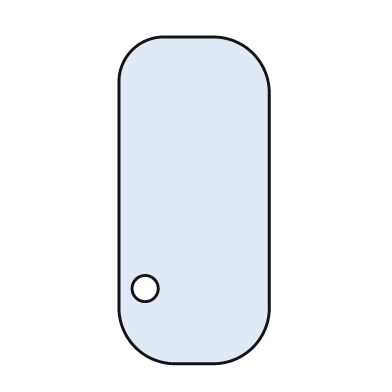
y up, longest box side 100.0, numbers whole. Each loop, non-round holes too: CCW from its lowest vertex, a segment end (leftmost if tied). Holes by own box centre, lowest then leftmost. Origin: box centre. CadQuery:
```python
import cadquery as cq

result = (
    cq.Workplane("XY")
    .moveTo(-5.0, -50.0)
    .lineTo(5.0, -50.0)
    .threePointArc((18.0, -45.0), (23.0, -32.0))
    .lineTo(23.0, 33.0)
    .threePointArc((18.0, 45.0), (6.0, 50.0))
    .lineTo(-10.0, 50.0)
    .threePointArc((-19.0, 46.0), (-23.0, 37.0))
    .lineTo(-23.0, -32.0)
    .threePointArc((-18.0, -45.0), (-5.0, -50.0))
    .close()
    .moveTo(-15.0, -27.0)
    .circle(4.0)
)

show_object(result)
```